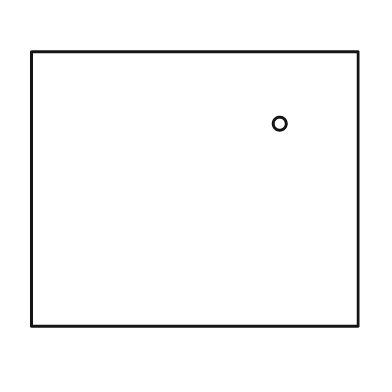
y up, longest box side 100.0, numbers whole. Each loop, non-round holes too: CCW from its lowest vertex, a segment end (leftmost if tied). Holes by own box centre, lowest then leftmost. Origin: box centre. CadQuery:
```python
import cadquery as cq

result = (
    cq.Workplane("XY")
    .moveTo(-50.0, -42.0)
    .lineTo(50.0, -42.0)
    .lineTo(50.0, 42.0)
    .lineTo(-50.0, 42.0)
    .close()
    .moveTo(26.0, 20.0)
    .circle(2.0)
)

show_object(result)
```